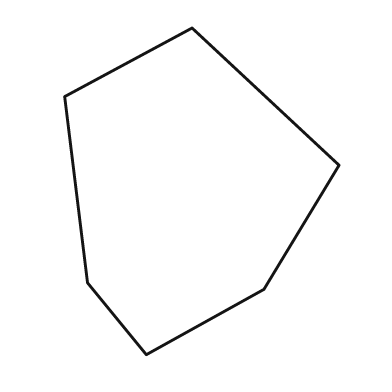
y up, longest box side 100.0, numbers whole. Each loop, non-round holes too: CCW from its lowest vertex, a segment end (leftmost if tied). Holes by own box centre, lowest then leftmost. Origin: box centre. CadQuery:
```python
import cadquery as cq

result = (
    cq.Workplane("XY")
    .moveTo(-17.0, -50.0)
    .lineTo(19.0, -30.0)
    .lineTo(42.0, 8.0)
    .lineTo(-3.0, 50.0)
    .lineTo(-42.0, 29.0)
    .lineTo(-35.0, -28.0)
    .close()
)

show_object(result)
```